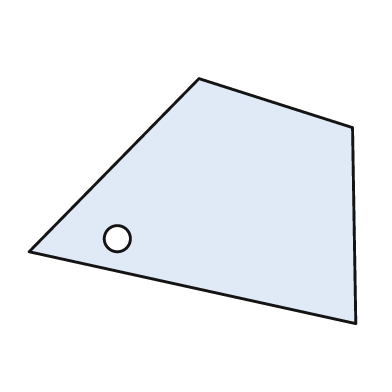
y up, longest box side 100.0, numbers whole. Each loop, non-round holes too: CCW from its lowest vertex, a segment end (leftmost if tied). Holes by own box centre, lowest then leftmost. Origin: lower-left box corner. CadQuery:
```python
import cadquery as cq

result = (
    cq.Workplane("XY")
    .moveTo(100.0, 0.0)
    .lineTo(99.0, 60.0)
    .lineTo(52.0, 75.0)
    .lineTo(0.0, 22.0)
    .close()
    .moveTo(27.0, 26.0)
    .circle(4.0)
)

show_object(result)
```